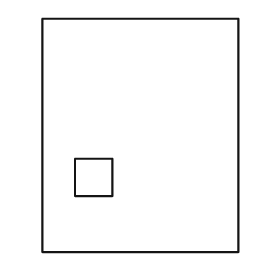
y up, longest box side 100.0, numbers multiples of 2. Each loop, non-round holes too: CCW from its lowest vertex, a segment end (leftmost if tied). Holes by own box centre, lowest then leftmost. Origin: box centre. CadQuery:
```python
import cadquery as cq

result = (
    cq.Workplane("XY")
    .moveTo(-42.0, -50.0)
    .lineTo(42.0, -50.0)
    .lineTo(42.0, 50.0)
    .lineTo(-42.0, 50.0)
    .close()
    .moveTo(-28.0, -26.0)
    .lineTo(-12.0, -26.0)
    .lineTo(-12.0, -10.0)
    .lineTo(-28.0, -10.0)
    .close()
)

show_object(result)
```